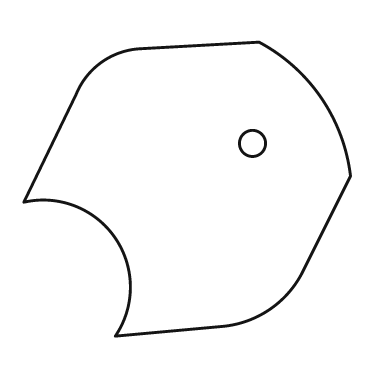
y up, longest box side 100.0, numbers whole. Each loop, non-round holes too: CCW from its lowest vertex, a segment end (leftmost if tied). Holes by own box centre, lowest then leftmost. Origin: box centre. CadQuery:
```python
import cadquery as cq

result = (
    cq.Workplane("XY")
    .moveTo(-22.0, -45.0)
    .lineTo(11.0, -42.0)
    .threePointArc((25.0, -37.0), (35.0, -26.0))
    .lineTo(50.0, 4.0)
    .threePointArc((41.0, 28.0), (22.0, 45.0))
    .lineTo(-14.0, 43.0)
    .threePointArc((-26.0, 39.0), (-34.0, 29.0))
    .lineTo(-50.0, -4.0)
    .threePointArc((-22.0, -15.0), (-22.0, -45.0))
    .close()
    .moveTo(20.0, 14.0)
    .circle(4.0)
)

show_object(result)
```